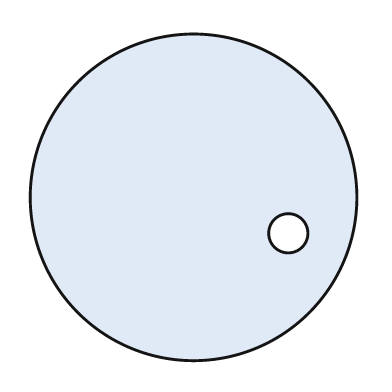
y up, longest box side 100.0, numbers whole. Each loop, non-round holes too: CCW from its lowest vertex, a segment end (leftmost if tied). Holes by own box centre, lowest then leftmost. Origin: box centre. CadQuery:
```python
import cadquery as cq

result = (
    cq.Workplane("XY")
    .moveTo(0.0, 0.0)
    .circle(50.0)
    .moveTo(29.0, -11.0)
    .circle(6.0)
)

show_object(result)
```